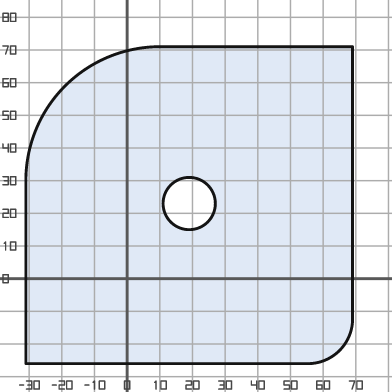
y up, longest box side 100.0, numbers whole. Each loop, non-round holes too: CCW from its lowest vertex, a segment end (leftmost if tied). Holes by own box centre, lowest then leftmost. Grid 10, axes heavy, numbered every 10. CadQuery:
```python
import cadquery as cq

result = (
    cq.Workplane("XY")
    .moveTo(-31.0, -26.0)
    .lineTo(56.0, -26.0)
    .threePointArc((65.0, -22.0), (69.0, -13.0))
    .lineTo(69.0, 71.0)
    .lineTo(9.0, 71.0)
    .threePointArc((-19.0, 59.0), (-31.0, 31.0))
    .close()
    .moveTo(19.0, 23.0)
    .circle(8.0)
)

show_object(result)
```